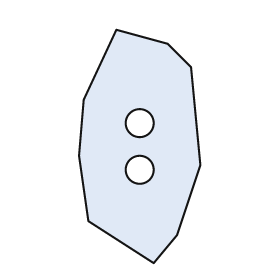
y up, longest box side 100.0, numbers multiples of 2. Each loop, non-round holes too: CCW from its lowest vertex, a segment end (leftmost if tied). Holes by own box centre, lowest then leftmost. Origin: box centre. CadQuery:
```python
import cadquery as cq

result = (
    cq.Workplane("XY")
    .moveTo(6.0, -50.0)
    .lineTo(16.0, -38.0)
    .lineTo(26.0, -8.0)
    .lineTo(22.0, 34.0)
    .lineTo(12.0, 44.0)
    .lineTo(-10.0, 50.0)
    .lineTo(-24.0, 20.0)
    .lineTo(-26.0, -4.0)
    .lineTo(-22.0, -32.0)
    .close()
    .moveTo(0.0, -10.0)
    .circle(6.0)
    .moveTo(0.0, 10.0)
    .circle(6.0)
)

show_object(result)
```